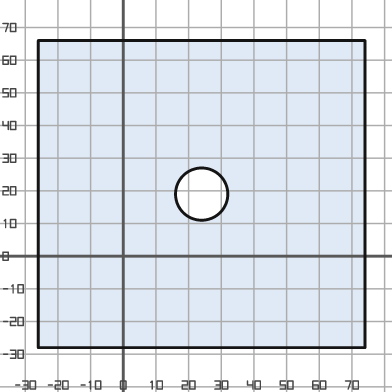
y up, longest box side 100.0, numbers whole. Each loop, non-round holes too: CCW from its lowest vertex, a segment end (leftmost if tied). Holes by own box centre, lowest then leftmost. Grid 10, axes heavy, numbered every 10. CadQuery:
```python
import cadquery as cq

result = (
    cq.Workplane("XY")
    .moveTo(-26.0, -28.0)
    .lineTo(74.0, -28.0)
    .lineTo(74.0, 66.0)
    .lineTo(-26.0, 66.0)
    .close()
    .moveTo(24.0, 19.0)
    .circle(8.0)
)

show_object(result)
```